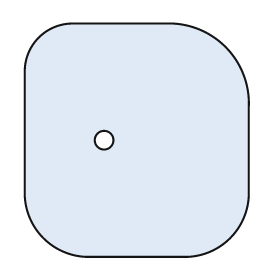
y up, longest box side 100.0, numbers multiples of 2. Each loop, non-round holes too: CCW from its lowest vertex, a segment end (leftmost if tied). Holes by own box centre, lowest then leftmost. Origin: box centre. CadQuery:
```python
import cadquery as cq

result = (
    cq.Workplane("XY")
    .moveTo(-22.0, -50.0)
    .lineTo(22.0, -50.0)
    .threePointArc((40.0, -42.0), (48.0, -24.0))
    .lineTo(48.0, 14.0)
    .threePointArc((38.0, 40.0), (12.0, 50.0))
    .lineTo(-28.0, 50.0)
    .threePointArc((-42.0, 44.0), (-48.0, 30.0))
    .lineTo(-48.0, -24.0)
    .threePointArc((-40.0, -42.0), (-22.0, -50.0))
    .close()
    .moveTo(-14.0, 0.0)
    .circle(4.0)
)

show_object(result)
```